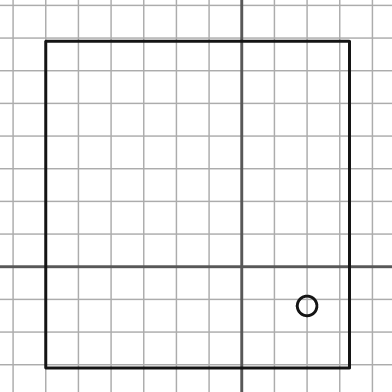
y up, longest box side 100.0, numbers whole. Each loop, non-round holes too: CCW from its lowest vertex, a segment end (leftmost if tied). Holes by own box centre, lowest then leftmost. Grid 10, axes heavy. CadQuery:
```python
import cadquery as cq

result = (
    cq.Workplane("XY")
    .moveTo(-60.0, -31.0)
    .lineTo(33.0, -31.0)
    .lineTo(33.0, 69.0)
    .lineTo(-60.0, 69.0)
    .close()
    .moveTo(20.0, -12.0)
    .circle(3.0)
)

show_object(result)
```